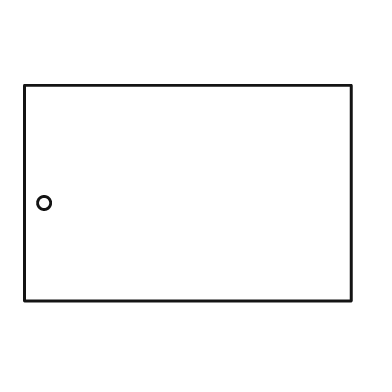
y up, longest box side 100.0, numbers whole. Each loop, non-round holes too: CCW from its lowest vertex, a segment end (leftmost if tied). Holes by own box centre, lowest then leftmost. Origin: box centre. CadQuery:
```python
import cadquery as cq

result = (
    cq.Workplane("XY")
    .moveTo(-50.0, -33.0)
    .lineTo(50.0, -33.0)
    .lineTo(50.0, 33.0)
    .lineTo(-50.0, 33.0)
    .close()
    .moveTo(-44.0, -3.0)
    .circle(2.0)
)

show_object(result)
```